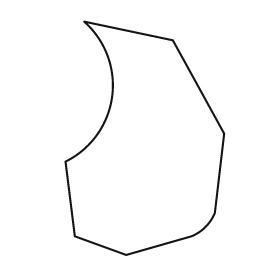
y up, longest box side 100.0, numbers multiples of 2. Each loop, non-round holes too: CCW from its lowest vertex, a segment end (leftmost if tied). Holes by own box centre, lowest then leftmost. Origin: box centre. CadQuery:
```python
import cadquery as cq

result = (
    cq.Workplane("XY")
    .moveTo(-8.0, -50.0)
    .lineTo(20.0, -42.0)
    .threePointArc((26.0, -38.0), (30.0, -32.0))
    .lineTo(34.0, 2.0)
    .lineTo(12.0, 42.0)
    .lineTo(-26.0, 50.0)
    .threePointArc((-14.0, 18.0), (-34.0, -10.0))
    .lineTo(-30.0, -42.0)
    .close()
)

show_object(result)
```